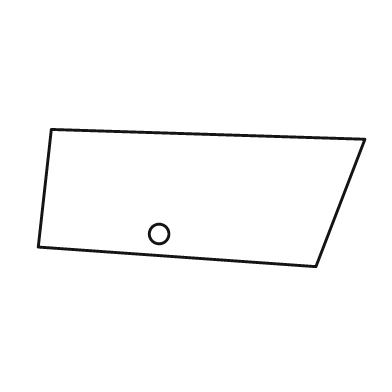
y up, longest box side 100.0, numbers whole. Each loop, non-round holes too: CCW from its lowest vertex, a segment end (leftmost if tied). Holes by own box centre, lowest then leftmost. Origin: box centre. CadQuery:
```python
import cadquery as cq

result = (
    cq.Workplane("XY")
    .moveTo(35.0, -21.0)
    .lineTo(50.0, 18.0)
    .lineTo(-46.0, 21.0)
    .lineTo(-50.0, -15.0)
    .close()
    .moveTo(-13.0, -11.0)
    .circle(3.0)
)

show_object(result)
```